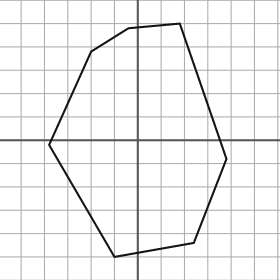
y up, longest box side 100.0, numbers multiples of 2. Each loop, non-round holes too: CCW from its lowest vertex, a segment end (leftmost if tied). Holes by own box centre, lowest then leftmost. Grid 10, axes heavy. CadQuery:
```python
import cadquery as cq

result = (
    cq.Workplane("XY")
    .moveTo(-10.0, -50.0)
    .lineTo(24.0, -44.0)
    .lineTo(38.0, -8.0)
    .lineTo(18.0, 50.0)
    .lineTo(-4.0, 48.0)
    .lineTo(-20.0, 38.0)
    .lineTo(-38.0, -2.0)
    .close()
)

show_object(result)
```